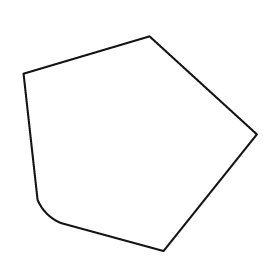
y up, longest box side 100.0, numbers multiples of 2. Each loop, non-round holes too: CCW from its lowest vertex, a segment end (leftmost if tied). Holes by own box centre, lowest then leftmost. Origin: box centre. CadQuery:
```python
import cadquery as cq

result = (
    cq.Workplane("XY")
    .moveTo(10.0, -46.0)
    .lineTo(50.0, 4.0)
    .lineTo(4.0, 46.0)
    .lineTo(-50.0, 30.0)
    .lineTo(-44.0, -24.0)
    .threePointArc((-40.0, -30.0), (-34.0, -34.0))
    .close()
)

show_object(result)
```